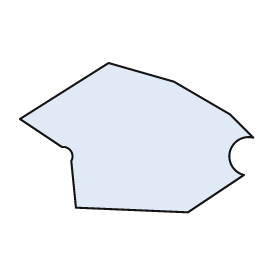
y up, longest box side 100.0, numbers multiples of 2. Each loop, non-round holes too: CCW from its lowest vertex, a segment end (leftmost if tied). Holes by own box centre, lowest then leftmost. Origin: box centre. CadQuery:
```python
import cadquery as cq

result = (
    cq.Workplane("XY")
    .moveTo(22.0, -32.0)
    .lineTo(46.0, -16.0)
    .threePointArc((40.0, -6.0), (50.0, 0.0))
    .lineTo(40.0, 10.0)
    .lineTo(16.0, 24.0)
    .lineTo(-12.0, 32.0)
    .lineTo(-50.0, 8.0)
    .lineTo(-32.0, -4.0)
    .threePointArc((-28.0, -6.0), (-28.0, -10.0))
    .lineTo(-26.0, -30.0)
    .close()
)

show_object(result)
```